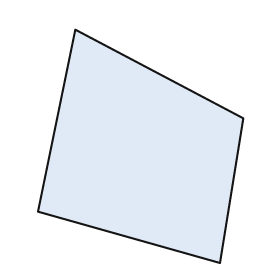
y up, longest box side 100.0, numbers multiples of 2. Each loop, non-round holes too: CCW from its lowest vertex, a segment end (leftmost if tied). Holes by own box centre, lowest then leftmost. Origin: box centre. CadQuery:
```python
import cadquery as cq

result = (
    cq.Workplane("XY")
    .moveTo(34.0, -50.0)
    .lineTo(44.0, 12.0)
    .lineTo(-28.0, 50.0)
    .lineTo(-44.0, -28.0)
    .close()
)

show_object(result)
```